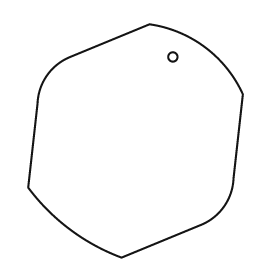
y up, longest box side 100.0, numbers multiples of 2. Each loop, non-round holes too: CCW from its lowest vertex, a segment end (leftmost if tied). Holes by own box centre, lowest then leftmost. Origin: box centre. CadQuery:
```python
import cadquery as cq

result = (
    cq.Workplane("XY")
    .moveTo(-6.0, -50.0)
    .lineTo(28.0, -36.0)
    .threePointArc((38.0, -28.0), (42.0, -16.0))
    .lineTo(46.0, 20.0)
    .threePointArc((30.0, 40.0), (6.0, 50.0))
    .lineTo(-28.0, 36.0)
    .threePointArc((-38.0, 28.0), (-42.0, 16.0))
    .lineTo(-46.0, -20.0)
    .threePointArc((-28.0, -38.0), (-6.0, -50.0))
    .close()
    .moveTo(16.0, 36.0)
    .circle(2.0)
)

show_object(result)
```